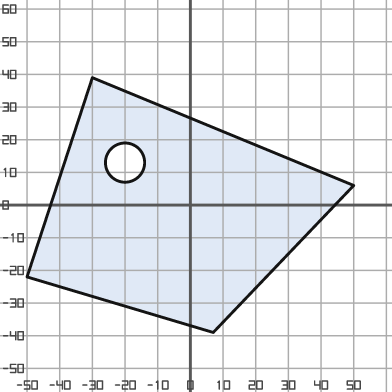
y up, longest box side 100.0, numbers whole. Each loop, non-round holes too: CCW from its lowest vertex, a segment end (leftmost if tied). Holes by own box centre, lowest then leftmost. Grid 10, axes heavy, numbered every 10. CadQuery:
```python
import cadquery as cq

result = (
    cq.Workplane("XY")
    .moveTo(7.0, -39.0)
    .lineTo(50.0, 6.0)
    .lineTo(-30.0, 39.0)
    .lineTo(-50.0, -22.0)
    .close()
    .moveTo(-20.0, 13.0)
    .circle(6.0)
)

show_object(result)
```